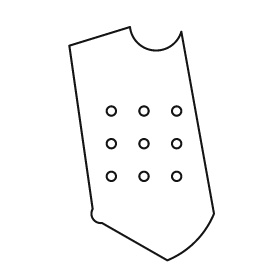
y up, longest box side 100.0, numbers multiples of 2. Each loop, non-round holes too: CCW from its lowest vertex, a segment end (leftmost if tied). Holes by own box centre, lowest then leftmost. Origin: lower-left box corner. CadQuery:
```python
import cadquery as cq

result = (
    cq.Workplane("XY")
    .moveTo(42.0, 0.0)
    .threePointArc((54.0, 8.0), (62.0, 20.0))
    .lineTo(48.0, 98.0)
    .threePointArc((36.0, 90.0), (26.0, 100.0))
    .lineTo(0.0, 92.0)
    .lineTo(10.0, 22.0)
    .threePointArc((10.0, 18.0), (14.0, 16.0))
    .close()
    .moveTo(18.0, 36.0)
    .circle(2.0)
    .moveTo(32.0, 36.0)
    .circle(2.0)
    .moveTo(46.0, 36.0)
    .circle(2.0)
    .moveTo(18.0, 50.0)
    .circle(2.0)
    .moveTo(32.0, 50.0)
    .circle(2.0)
    .moveTo(46.0, 50.0)
    .circle(2.0)
    .moveTo(18.0, 64.0)
    .circle(2.0)
    .moveTo(32.0, 64.0)
    .circle(2.0)
    .moveTo(46.0, 64.0)
    .circle(2.0)
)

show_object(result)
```